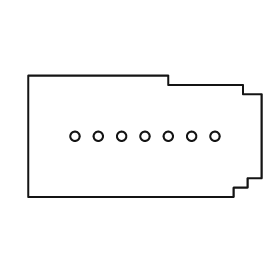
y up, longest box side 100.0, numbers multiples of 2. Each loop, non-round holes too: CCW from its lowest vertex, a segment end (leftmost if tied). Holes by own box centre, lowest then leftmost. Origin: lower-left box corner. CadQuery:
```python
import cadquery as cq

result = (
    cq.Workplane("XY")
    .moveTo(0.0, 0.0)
    .lineTo(88.0, 0.0)
    .lineTo(88.0, 4.0)
    .lineTo(94.0, 4.0)
    .lineTo(94.0, 8.0)
    .lineTo(100.0, 8.0)
    .lineTo(100.0, 44.0)
    .lineTo(92.0, 44.0)
    .lineTo(92.0, 48.0)
    .lineTo(60.0, 48.0)
    .lineTo(60.0, 52.0)
    .lineTo(0.0, 52.0)
    .close()
    .moveTo(20.0, 26.0)
    .circle(2.0)
    .moveTo(30.0, 26.0)
    .circle(2.0)
    .moveTo(40.0, 26.0)
    .circle(2.0)
    .moveTo(50.0, 26.0)
    .circle(2.0)
    .moveTo(60.0, 26.0)
    .circle(2.0)
    .moveTo(70.0, 26.0)
    .circle(2.0)
    .moveTo(80.0, 26.0)
    .circle(2.0)
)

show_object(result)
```